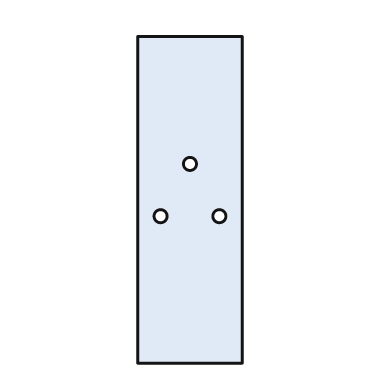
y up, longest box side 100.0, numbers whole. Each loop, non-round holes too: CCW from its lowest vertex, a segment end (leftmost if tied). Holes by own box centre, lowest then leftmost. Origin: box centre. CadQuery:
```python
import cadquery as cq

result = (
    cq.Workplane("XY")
    .moveTo(-16.0, -50.0)
    .lineTo(16.0, -50.0)
    .lineTo(16.0, 50.0)
    .lineTo(-16.0, 50.0)
    .close()
    .moveTo(-9.0, -5.0)
    .circle(2.0)
    .moveTo(9.0, -5.0)
    .circle(2.0)
    .moveTo(0.0, 11.0)
    .circle(2.0)
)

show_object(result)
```